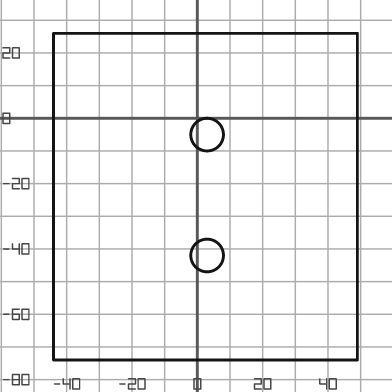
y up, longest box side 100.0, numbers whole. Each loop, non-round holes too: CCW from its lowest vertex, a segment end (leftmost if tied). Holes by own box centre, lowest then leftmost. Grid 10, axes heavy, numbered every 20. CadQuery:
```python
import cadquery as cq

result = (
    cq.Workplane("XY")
    .moveTo(-44.0, -74.0)
    .lineTo(49.0, -74.0)
    .lineTo(49.0, 26.0)
    .lineTo(-44.0, 26.0)
    .close()
    .moveTo(3.0, -42.0)
    .circle(5.0)
    .moveTo(3.0, -5.0)
    .circle(5.0)
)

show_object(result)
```